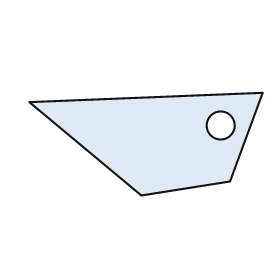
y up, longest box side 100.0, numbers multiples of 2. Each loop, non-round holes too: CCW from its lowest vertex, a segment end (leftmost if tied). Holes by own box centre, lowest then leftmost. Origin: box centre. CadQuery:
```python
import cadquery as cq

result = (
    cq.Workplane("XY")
    .moveTo(-2.0, -22.0)
    .lineTo(36.0, -16.0)
    .lineTo(50.0, 22.0)
    .lineTo(-50.0, 18.0)
    .close()
    .moveTo(32.0, 8.0)
    .circle(6.0)
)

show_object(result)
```